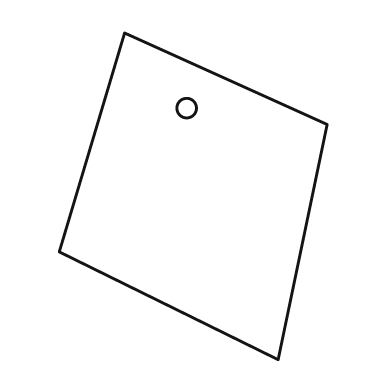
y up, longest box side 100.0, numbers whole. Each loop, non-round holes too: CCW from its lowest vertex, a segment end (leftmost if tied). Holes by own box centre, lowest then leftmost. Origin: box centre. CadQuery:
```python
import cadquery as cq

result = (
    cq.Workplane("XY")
    .moveTo(26.0, -50.0)
    .lineTo(41.0, 22.0)
    .lineTo(-21.0, 50.0)
    .lineTo(-41.0, -17.0)
    .close()
    .moveTo(-2.0, 27.0)
    .circle(3.0)
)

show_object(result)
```